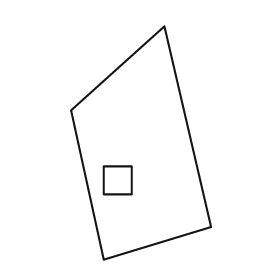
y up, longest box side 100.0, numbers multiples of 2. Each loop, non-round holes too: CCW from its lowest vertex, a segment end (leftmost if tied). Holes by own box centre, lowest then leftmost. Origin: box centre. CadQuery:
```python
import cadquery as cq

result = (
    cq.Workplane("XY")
    .moveTo(-16.0, -50.0)
    .lineTo(30.0, -36.0)
    .lineTo(10.0, 50.0)
    .lineTo(-30.0, 14.0)
    .close()
    .moveTo(-16.0, -22.0)
    .lineTo(-4.0, -22.0)
    .lineTo(-4.0, -10.0)
    .lineTo(-16.0, -10.0)
    .close()
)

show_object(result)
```